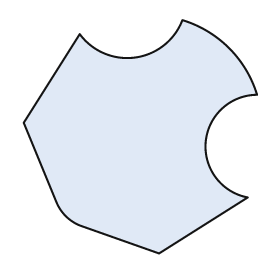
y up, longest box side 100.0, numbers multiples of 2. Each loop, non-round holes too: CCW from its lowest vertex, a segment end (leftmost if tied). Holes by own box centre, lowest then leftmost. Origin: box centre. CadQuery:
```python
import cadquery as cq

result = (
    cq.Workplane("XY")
    .moveTo(8.0, -50.0)
    .lineTo(46.0, -26.0)
    .threePointArc((28.0, -2.0), (50.0, 18.0))
    .threePointArc((38.0, 38.0), (18.0, 50.0))
    .threePointArc((-2.0, 34.0), (-26.0, 44.0))
    .lineTo(-50.0, 6.0)
    .lineTo(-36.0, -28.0)
    .threePointArc((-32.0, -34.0), (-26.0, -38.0))
    .close()
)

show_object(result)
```